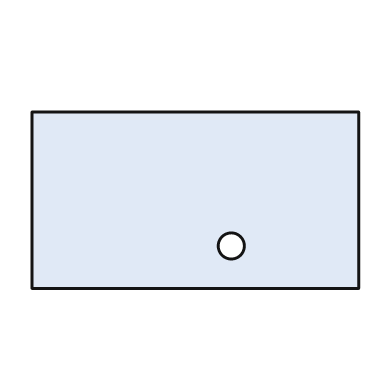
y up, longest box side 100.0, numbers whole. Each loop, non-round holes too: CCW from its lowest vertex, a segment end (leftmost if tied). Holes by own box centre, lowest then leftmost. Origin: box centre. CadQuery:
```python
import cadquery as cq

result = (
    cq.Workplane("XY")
    .moveTo(-50.0, -27.0)
    .lineTo(50.0, -27.0)
    .lineTo(50.0, 27.0)
    .lineTo(-50.0, 27.0)
    .close()
    .moveTo(11.0, -14.0)
    .circle(4.0)
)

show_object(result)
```